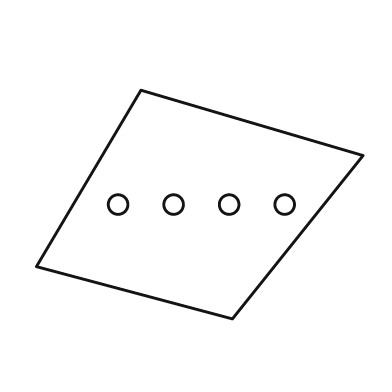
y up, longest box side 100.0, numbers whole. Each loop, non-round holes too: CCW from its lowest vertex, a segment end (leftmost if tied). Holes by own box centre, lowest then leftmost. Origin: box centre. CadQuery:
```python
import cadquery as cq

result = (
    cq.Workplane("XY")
    .moveTo(10.0, -35.0)
    .lineTo(50.0, 15.0)
    .lineTo(-18.0, 35.0)
    .lineTo(-50.0, -19.0)
    .close()
    .moveTo(-25.0, 0.0)
    .circle(3.0)
    .moveTo(-8.0, 0.0)
    .circle(3.0)
    .moveTo(9.0, 0.0)
    .circle(3.0)
    .moveTo(26.0, 0.0)
    .circle(3.0)
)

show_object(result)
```